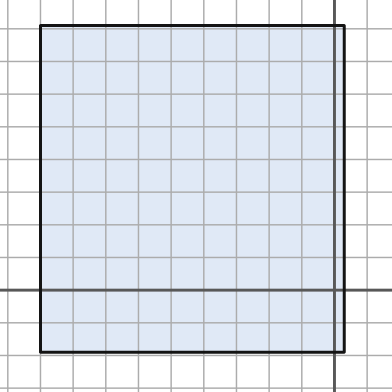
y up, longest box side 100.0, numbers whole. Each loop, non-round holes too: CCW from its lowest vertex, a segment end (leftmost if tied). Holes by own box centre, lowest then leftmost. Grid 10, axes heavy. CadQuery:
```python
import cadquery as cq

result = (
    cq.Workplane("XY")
    .moveTo(-90.0, -19.0)
    .lineTo(3.0, -19.0)
    .lineTo(3.0, 81.0)
    .lineTo(-90.0, 81.0)
    .close()
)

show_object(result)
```